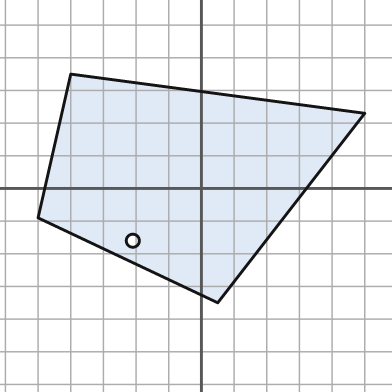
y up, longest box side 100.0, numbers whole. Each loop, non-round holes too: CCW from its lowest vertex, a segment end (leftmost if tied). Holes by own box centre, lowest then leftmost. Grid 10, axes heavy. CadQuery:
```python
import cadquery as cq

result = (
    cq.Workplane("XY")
    .moveTo(5.0, -35.0)
    .lineTo(50.0, 23.0)
    .lineTo(-40.0, 35.0)
    .lineTo(-50.0, -9.0)
    .close()
    .moveTo(-21.0, -16.0)
    .circle(2.0)
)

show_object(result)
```